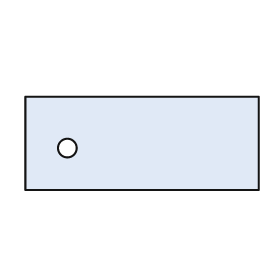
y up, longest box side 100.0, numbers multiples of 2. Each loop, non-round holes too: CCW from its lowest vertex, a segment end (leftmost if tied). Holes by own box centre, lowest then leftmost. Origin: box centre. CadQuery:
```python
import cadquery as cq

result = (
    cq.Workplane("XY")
    .moveTo(-50.0, -20.0)
    .lineTo(50.0, -20.0)
    .lineTo(50.0, 20.0)
    .lineTo(-50.0, 20.0)
    .close()
    .moveTo(-32.0, -2.0)
    .circle(4.0)
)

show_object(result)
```